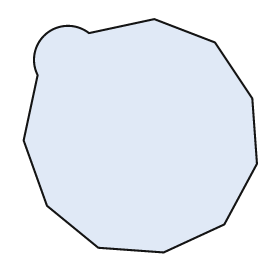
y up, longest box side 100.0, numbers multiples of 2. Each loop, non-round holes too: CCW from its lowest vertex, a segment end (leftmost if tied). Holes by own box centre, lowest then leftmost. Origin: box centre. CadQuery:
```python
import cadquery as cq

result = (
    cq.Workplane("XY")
    .moveTo(10.0, -50.0)
    .lineTo(36.0, -38.0)
    .lineTo(50.0, -12.0)
    .lineTo(48.0, 16.0)
    .lineTo(32.0, 40.0)
    .lineTo(6.0, 50.0)
    .lineTo(-22.0, 44.0)
    .threePointArc((-40.0, 44.0), (-44.0, 26.0))
    .lineTo(-50.0, -2.0)
    .lineTo(-40.0, -30.0)
    .lineTo(-18.0, -48.0)
    .close()
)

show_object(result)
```